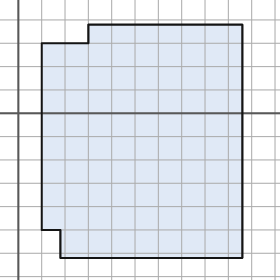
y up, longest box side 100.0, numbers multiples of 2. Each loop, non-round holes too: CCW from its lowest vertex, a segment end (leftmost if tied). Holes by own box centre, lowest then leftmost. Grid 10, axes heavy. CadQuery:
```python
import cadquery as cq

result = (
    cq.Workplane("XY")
    .moveTo(18.0, -62.0)
    .lineTo(96.0, -62.0)
    .lineTo(96.0, 38.0)
    .lineTo(30.0, 38.0)
    .lineTo(30.0, 30.0)
    .lineTo(10.0, 30.0)
    .lineTo(10.0, -50.0)
    .lineTo(18.0, -50.0)
    .close()
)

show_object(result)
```